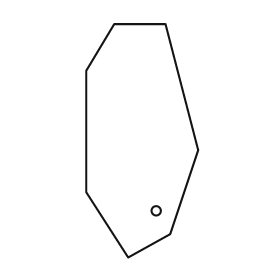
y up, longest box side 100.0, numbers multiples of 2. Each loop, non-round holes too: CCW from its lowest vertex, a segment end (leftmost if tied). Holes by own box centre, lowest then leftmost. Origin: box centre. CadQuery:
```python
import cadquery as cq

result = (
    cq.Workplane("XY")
    .moveTo(-6.0, -50.0)
    .lineTo(12.0, -40.0)
    .lineTo(24.0, -4.0)
    .lineTo(10.0, 50.0)
    .lineTo(-12.0, 50.0)
    .lineTo(-24.0, 30.0)
    .lineTo(-24.0, -22.0)
    .close()
    .moveTo(6.0, -30.0)
    .circle(2.0)
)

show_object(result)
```